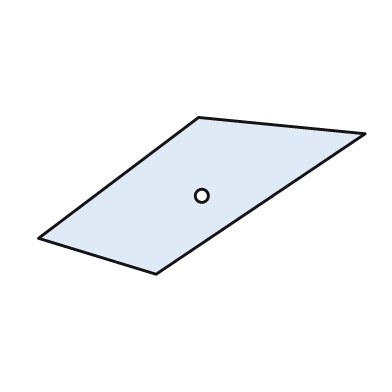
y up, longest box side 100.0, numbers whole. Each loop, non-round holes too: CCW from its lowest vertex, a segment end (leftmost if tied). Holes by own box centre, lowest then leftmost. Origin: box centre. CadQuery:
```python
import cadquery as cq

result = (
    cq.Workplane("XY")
    .moveTo(-14.0, -24.0)
    .lineTo(50.0, 19.0)
    .lineTo(-1.0, 24.0)
    .lineTo(-50.0, -13.0)
    .close()
    .moveTo(0.0, 0.0)
    .circle(2.0)
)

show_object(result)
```